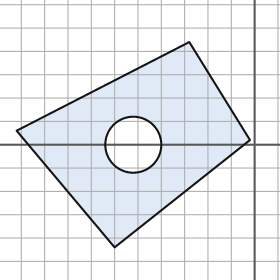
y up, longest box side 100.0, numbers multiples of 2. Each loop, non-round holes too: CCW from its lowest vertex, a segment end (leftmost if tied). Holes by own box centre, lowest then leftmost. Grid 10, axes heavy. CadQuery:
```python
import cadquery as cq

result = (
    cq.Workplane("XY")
    .moveTo(-60.0, -44.0)
    .lineTo(-2.0, 2.0)
    .lineTo(-28.0, 44.0)
    .lineTo(-102.0, 6.0)
    .close()
    .moveTo(-52.0, 0.0)
    .circle(12.0)
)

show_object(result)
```